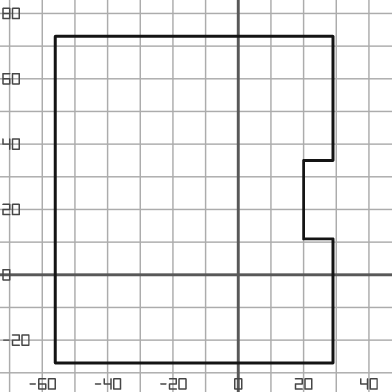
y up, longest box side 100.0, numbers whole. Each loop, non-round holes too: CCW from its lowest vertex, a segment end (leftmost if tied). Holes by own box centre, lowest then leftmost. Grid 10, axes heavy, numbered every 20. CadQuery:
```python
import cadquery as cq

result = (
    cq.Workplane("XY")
    .moveTo(-56.0, -27.0)
    .lineTo(29.0, -27.0)
    .lineTo(29.0, 11.0)
    .lineTo(20.0, 11.0)
    .lineTo(20.0, 35.0)
    .lineTo(29.0, 35.0)
    .lineTo(29.0, 73.0)
    .lineTo(-56.0, 73.0)
    .close()
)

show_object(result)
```